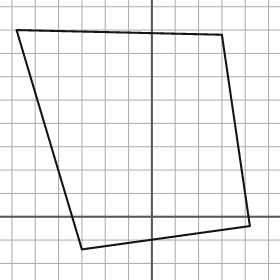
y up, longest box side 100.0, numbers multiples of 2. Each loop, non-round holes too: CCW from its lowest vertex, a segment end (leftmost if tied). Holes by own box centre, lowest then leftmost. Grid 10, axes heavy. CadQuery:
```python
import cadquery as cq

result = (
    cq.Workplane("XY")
    .moveTo(-30.0, -14.0)
    .lineTo(42.0, -4.0)
    .lineTo(30.0, 78.0)
    .lineTo(-58.0, 80.0)
    .close()
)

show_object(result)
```